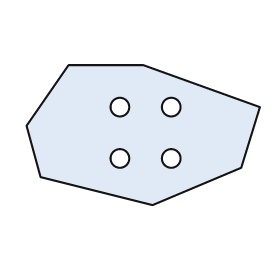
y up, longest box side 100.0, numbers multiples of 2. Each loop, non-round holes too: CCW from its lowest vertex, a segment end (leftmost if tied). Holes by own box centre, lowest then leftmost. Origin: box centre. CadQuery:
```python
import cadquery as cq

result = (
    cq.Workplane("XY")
    .moveTo(4.0, -30.0)
    .lineTo(42.0, -14.0)
    .lineTo(50.0, 12.0)
    .lineTo(0.0, 30.0)
    .lineTo(-32.0, 30.0)
    .lineTo(-50.0, 4.0)
    .lineTo(-44.0, -18.0)
    .close()
    .moveTo(-10.0, -10.0)
    .circle(4.0)
    .moveTo(12.0, -10.0)
    .circle(4.0)
    .moveTo(-10.0, 12.0)
    .circle(4.0)
    .moveTo(12.0, 12.0)
    .circle(4.0)
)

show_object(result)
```